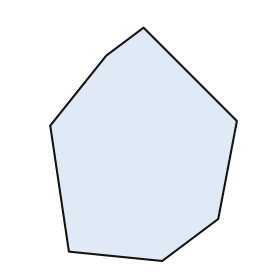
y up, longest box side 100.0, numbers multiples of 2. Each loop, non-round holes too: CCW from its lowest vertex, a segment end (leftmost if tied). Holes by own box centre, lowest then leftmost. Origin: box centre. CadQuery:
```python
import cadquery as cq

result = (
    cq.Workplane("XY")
    .moveTo(8.0, -50.0)
    .lineTo(32.0, -32.0)
    .lineTo(40.0, 10.0)
    .lineTo(0.0, 50.0)
    .lineTo(-16.0, 38.0)
    .lineTo(-40.0, 8.0)
    .lineTo(-32.0, -46.0)
    .close()
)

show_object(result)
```